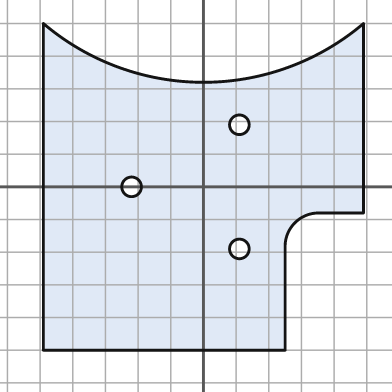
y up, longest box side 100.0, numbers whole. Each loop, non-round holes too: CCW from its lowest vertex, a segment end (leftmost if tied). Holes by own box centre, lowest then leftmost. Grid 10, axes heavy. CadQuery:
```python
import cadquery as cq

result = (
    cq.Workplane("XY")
    .moveTo(-49.0, -50.0)
    .lineTo(25.0, -50.0)
    .lineTo(25.0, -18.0)
    .threePointArc((28.0, -11.0), (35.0, -8.0))
    .lineTo(49.0, -8.0)
    .lineTo(49.0, 50.0)
    .threePointArc((0.0, 32.0), (-49.0, 50.0))
    .close()
    .moveTo(11.0, -19.0)
    .circle(3.0)
    .moveTo(-22.0, 0.0)
    .circle(3.0)
    .moveTo(11.0, 19.0)
    .circle(3.0)
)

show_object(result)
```